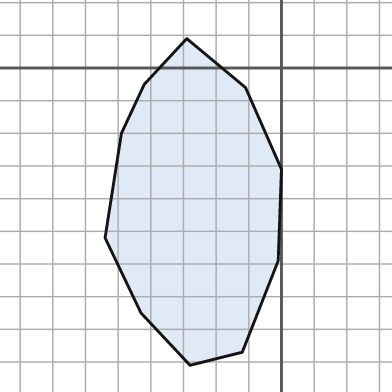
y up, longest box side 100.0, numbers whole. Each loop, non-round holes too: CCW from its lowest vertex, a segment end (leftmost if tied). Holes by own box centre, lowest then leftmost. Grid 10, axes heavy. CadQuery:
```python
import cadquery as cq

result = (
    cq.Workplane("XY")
    .moveTo(-28.0, -91.0)
    .lineTo(-12.0, -87.0)
    .lineTo(-1.0, -59.0)
    .lineTo(0.0, -31.0)
    .lineTo(-11.0, -6.0)
    .lineTo(-29.0, 9.0)
    .lineTo(-42.0, -5.0)
    .lineTo(-49.0, -20.0)
    .lineTo(-54.0, -52.0)
    .lineTo(-43.0, -75.0)
    .close()
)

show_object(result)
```